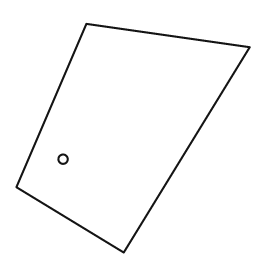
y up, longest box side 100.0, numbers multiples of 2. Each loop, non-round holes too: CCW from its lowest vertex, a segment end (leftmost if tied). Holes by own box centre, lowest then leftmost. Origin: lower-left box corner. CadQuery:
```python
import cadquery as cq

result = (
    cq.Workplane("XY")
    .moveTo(46.0, 0.0)
    .lineTo(100.0, 88.0)
    .lineTo(30.0, 98.0)
    .lineTo(0.0, 28.0)
    .close()
    .moveTo(20.0, 40.0)
    .circle(2.0)
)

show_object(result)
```